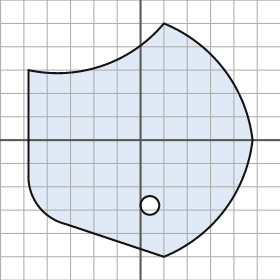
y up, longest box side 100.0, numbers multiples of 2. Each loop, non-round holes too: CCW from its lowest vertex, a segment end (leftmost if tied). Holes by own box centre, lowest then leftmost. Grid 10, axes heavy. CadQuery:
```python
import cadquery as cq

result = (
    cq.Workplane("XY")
    .moveTo(10.0, -50.0)
    .threePointArc((36.0, -30.0), (48.0, 0.0))
    .threePointArc((36.0, 30.0), (10.0, 50.0))
    .threePointArc((-16.0, 32.0), (-48.0, 30.0))
    .lineTo(-48.0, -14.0)
    .threePointArc((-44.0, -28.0), (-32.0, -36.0))
    .close()
    .moveTo(4.0, -28.0)
    .circle(4.0)
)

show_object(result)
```